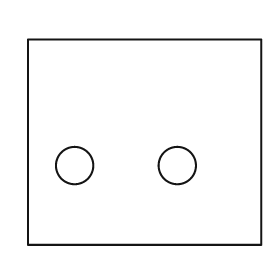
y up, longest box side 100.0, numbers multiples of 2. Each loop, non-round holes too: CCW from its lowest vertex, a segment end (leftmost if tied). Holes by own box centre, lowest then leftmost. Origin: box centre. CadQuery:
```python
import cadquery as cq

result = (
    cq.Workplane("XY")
    .moveTo(-50.0, -44.0)
    .lineTo(50.0, -44.0)
    .lineTo(50.0, 44.0)
    .lineTo(-50.0, 44.0)
    .close()
    .moveTo(-30.0, -10.0)
    .circle(8.0)
    .moveTo(14.0, -10.0)
    .circle(8.0)
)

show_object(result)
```